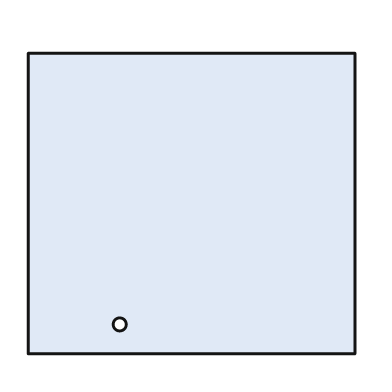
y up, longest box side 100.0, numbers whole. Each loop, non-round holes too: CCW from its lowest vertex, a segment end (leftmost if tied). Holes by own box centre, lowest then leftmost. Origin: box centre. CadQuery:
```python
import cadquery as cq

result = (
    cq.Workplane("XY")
    .moveTo(-50.0, -46.0)
    .lineTo(50.0, -46.0)
    .lineTo(50.0, 46.0)
    .lineTo(-50.0, 46.0)
    .close()
    .moveTo(-22.0, -37.0)
    .circle(2.0)
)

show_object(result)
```